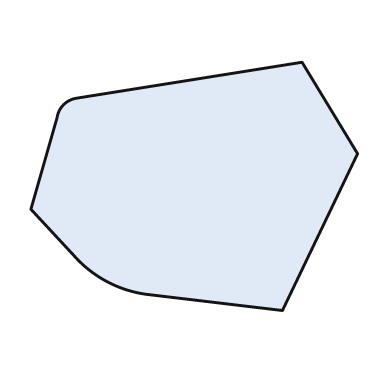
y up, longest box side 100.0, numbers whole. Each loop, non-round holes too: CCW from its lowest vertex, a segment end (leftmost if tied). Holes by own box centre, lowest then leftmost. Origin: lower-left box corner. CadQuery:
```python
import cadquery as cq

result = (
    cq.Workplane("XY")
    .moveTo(77.0, 0.0)
    .lineTo(100.0, 48.0)
    .lineTo(83.0, 76.0)
    .lineTo(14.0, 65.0)
    .threePointArc((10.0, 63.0), (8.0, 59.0))
    .lineTo(0.0, 31.0)
    .lineTo(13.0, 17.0)
    .threePointArc((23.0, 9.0), (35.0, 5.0))
    .close()
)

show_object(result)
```